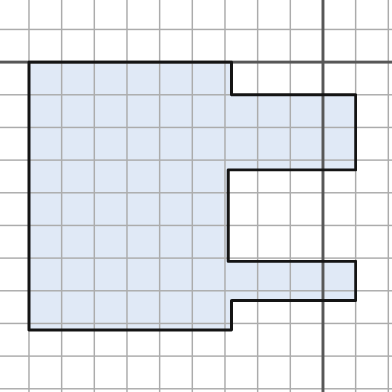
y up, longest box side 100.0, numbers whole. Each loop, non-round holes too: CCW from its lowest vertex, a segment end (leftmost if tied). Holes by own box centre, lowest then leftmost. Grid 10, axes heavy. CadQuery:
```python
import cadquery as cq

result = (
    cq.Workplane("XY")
    .moveTo(-90.0, -82.0)
    .lineTo(-28.0, -82.0)
    .lineTo(-28.0, -73.0)
    .lineTo(10.0, -73.0)
    .lineTo(10.0, -61.0)
    .lineTo(-29.0, -61.0)
    .lineTo(-29.0, -33.0)
    .lineTo(10.0, -33.0)
    .lineTo(10.0, -10.0)
    .lineTo(-28.0, -10.0)
    .lineTo(-28.0, 0.0)
    .lineTo(-90.0, 0.0)
    .close()
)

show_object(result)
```